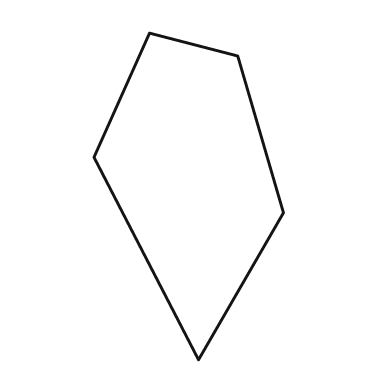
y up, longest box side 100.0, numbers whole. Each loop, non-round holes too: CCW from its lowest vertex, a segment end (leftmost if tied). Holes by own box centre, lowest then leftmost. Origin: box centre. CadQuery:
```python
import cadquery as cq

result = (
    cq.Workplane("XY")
    .moveTo(3.0, -50.0)
    .lineTo(29.0, -5.0)
    .lineTo(15.0, 43.0)
    .lineTo(-12.0, 50.0)
    .lineTo(-29.0, 12.0)
    .close()
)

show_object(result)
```